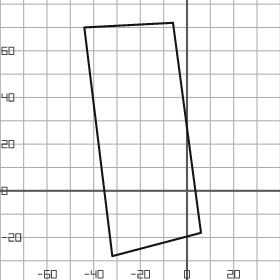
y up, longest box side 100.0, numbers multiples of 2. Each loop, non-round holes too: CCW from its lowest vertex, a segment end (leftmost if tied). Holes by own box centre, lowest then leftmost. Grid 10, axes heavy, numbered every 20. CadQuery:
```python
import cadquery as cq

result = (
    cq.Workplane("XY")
    .moveTo(-32.0, -28.0)
    .lineTo(6.0, -18.0)
    .lineTo(-6.0, 72.0)
    .lineTo(-44.0, 70.0)
    .close()
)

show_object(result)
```